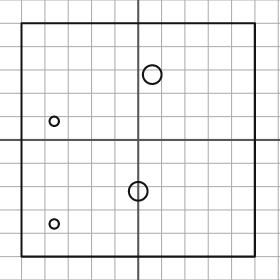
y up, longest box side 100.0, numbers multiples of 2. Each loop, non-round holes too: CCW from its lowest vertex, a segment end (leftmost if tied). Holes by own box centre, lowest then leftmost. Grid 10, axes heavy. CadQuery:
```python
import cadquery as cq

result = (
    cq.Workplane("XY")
    .moveTo(-50.0, -50.0)
    .lineTo(50.0, -50.0)
    .lineTo(50.0, 50.0)
    .lineTo(-50.0, 50.0)
    .close()
    .moveTo(-36.0, -36.0)
    .circle(2.0)
    .moveTo(0.0, -22.0)
    .circle(4.0)
    .moveTo(-36.0, 8.0)
    .circle(2.0)
    .moveTo(6.0, 28.0)
    .circle(4.0)
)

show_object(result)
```